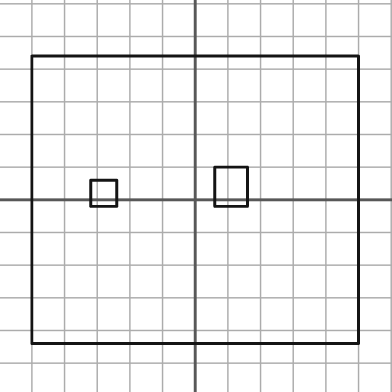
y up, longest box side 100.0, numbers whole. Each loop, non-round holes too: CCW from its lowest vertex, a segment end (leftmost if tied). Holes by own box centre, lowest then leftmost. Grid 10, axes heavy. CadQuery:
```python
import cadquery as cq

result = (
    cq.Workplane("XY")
    .moveTo(-50.0, -44.0)
    .lineTo(50.0, -44.0)
    .lineTo(50.0, 44.0)
    .lineTo(-50.0, 44.0)
    .close()
    .moveTo(-32.0, -2.0)
    .lineTo(-24.0, -2.0)
    .lineTo(-24.0, 6.0)
    .lineTo(-32.0, 6.0)
    .close()
    .moveTo(6.0, -2.0)
    .lineTo(16.0, -2.0)
    .lineTo(16.0, 10.0)
    .lineTo(6.0, 10.0)
    .close()
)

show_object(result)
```